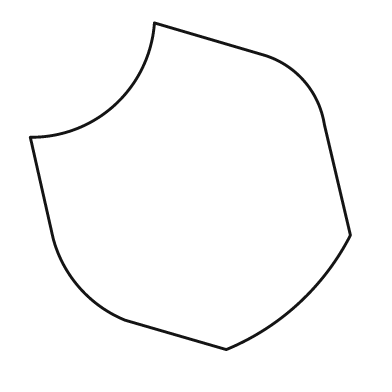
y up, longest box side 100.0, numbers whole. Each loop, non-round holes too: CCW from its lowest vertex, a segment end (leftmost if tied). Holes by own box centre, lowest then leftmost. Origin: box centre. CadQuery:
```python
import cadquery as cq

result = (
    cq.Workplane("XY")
    .moveTo(11.0, -50.0)
    .threePointArc((33.0, -36.0), (49.0, -15.0))
    .lineTo(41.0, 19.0)
    .threePointArc((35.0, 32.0), (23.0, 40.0))
    .lineTo(-11.0, 50.0)
    .threePointArc((-23.0, 25.0), (-49.0, 15.0))
    .lineTo(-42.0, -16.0)
    .threePointArc((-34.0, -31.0), (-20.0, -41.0))
    .close()
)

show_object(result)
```